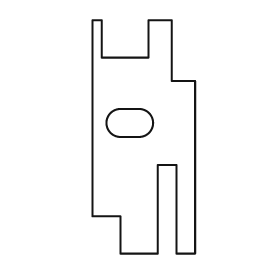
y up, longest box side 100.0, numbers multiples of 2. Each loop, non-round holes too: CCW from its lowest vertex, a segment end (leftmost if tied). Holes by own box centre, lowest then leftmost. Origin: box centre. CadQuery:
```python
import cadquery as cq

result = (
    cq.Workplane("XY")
    .moveTo(-10.0, -50.0)
    .lineTo(6.0, -50.0)
    .lineTo(6.0, -12.0)
    .lineTo(14.0, -12.0)
    .lineTo(14.0, -50.0)
    .lineTo(22.0, -50.0)
    .lineTo(22.0, 24.0)
    .lineTo(12.0, 24.0)
    .lineTo(12.0, 50.0)
    .lineTo(2.0, 50.0)
    .lineTo(2.0, 34.0)
    .lineTo(-18.0, 34.0)
    .lineTo(-18.0, 50.0)
    .lineTo(-22.0, 50.0)
    .lineTo(-22.0, -34.0)
    .lineTo(-10.0, -34.0)
    .close()
    .moveTo(-10.0, 0.0)
    .lineTo(-2.0, 0.0)
    .threePointArc((4.0, 6.0), (-2.0, 12.0))
    .lineTo(-10.0, 12.0)
    .threePointArc((-16.0, 6.0), (-10.0, 0.0))
    .close()
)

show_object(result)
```